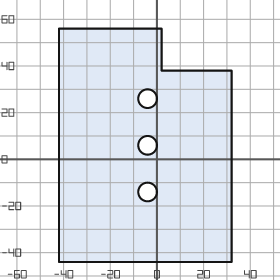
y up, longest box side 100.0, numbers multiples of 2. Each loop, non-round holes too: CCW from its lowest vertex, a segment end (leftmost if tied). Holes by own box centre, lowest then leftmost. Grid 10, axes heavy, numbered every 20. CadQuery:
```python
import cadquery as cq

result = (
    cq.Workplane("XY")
    .moveTo(-42.0, -44.0)
    .lineTo(32.0, -44.0)
    .lineTo(32.0, 38.0)
    .lineTo(2.0, 38.0)
    .lineTo(2.0, 56.0)
    .lineTo(-42.0, 56.0)
    .close()
    .moveTo(-4.0, -14.0)
    .circle(4.0)
    .moveTo(-4.0, 6.0)
    .circle(4.0)
    .moveTo(-4.0, 26.0)
    .circle(4.0)
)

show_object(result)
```